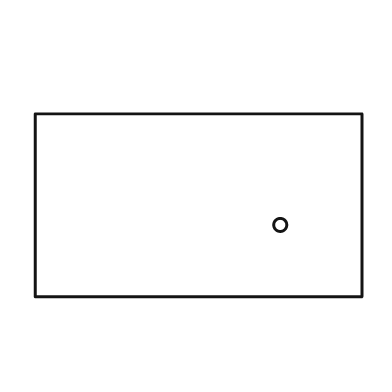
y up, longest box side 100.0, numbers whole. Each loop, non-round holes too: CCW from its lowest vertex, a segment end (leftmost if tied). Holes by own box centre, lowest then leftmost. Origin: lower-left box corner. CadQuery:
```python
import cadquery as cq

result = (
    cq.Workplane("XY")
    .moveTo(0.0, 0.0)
    .lineTo(100.0, 0.0)
    .lineTo(100.0, 56.0)
    .lineTo(0.0, 56.0)
    .close()
    .moveTo(75.0, 22.0)
    .circle(2.0)
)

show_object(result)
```